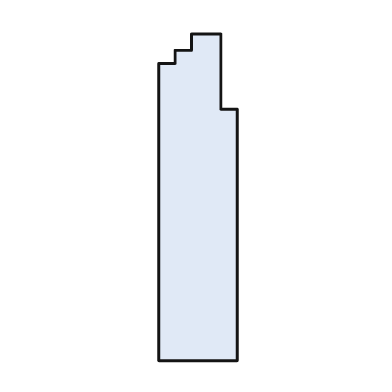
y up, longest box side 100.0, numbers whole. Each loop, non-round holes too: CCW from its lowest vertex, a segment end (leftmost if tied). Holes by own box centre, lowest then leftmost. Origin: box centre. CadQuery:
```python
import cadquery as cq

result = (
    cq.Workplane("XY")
    .moveTo(-12.0, -50.0)
    .lineTo(12.0, -50.0)
    .lineTo(12.0, 27.0)
    .lineTo(7.0, 27.0)
    .lineTo(7.0, 50.0)
    .lineTo(-2.0, 50.0)
    .lineTo(-2.0, 45.0)
    .lineTo(-7.0, 45.0)
    .lineTo(-7.0, 41.0)
    .lineTo(-12.0, 41.0)
    .close()
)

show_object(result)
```